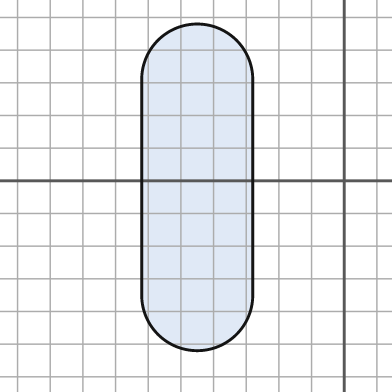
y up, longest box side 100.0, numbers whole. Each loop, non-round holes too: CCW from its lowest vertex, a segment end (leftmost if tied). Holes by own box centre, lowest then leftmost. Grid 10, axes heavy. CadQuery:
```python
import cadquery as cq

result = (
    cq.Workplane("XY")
    .moveTo(-62.0, -35.0)
    .threePointArc((-45.0, -52.0), (-28.0, -35.0))
    .lineTo(-28.0, 31.0)
    .threePointArc((-45.0, 48.0), (-62.0, 31.0))
    .close()
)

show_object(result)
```